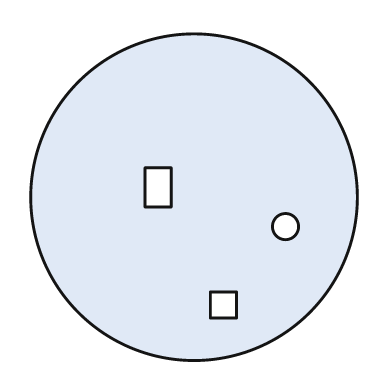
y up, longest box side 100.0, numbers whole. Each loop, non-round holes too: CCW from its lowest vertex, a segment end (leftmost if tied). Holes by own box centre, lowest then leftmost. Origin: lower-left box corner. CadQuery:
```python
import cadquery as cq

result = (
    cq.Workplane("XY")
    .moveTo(50.0, 50.0)
    .circle(50.0)
    .moveTo(55.0, 13.0)
    .lineTo(63.0, 13.0)
    .lineTo(63.0, 21.0)
    .lineTo(55.0, 21.0)
    .close()
    .moveTo(78.0, 41.0)
    .circle(4.0)
    .moveTo(35.0, 47.0)
    .lineTo(43.0, 47.0)
    .lineTo(43.0, 59.0)
    .lineTo(35.0, 59.0)
    .close()
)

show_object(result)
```